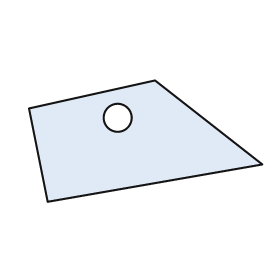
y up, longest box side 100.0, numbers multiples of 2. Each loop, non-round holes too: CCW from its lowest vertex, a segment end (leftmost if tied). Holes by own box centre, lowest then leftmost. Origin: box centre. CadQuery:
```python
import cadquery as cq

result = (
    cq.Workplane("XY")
    .moveTo(-42.0, -26.0)
    .lineTo(50.0, -10.0)
    .lineTo(4.0, 26.0)
    .lineTo(-50.0, 14.0)
    .close()
    .moveTo(-12.0, 10.0)
    .circle(6.0)
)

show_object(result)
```